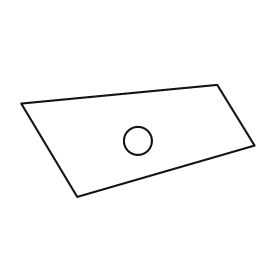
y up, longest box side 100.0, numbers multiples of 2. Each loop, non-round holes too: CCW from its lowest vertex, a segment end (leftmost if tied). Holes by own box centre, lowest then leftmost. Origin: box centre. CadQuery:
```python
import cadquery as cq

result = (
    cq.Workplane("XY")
    .moveTo(-26.0, -24.0)
    .lineTo(50.0, -2.0)
    .lineTo(34.0, 24.0)
    .lineTo(-50.0, 16.0)
    .close()
    .moveTo(0.0, 0.0)
    .circle(6.0)
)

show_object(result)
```